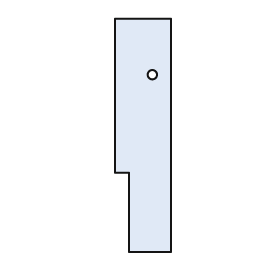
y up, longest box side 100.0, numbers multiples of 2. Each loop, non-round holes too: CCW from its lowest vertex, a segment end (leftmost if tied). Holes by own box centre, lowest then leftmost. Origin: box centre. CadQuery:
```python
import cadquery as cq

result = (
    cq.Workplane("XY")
    .moveTo(-6.0, -50.0)
    .lineTo(12.0, -50.0)
    .lineTo(12.0, 50.0)
    .lineTo(-12.0, 50.0)
    .lineTo(-12.0, -16.0)
    .lineTo(-6.0, -16.0)
    .close()
    .moveTo(4.0, 26.0)
    .circle(2.0)
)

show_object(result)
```